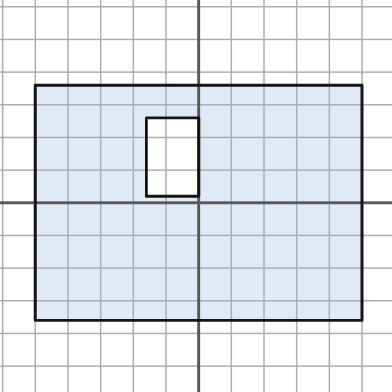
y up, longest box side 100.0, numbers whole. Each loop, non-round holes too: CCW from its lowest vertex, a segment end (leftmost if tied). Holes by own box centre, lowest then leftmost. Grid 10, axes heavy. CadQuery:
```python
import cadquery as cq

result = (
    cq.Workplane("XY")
    .moveTo(-50.0, -36.0)
    .lineTo(50.0, -36.0)
    .lineTo(50.0, 36.0)
    .lineTo(-50.0, 36.0)
    .close()
    .moveTo(-16.0, 2.0)
    .lineTo(0.0, 2.0)
    .lineTo(0.0, 26.0)
    .lineTo(-16.0, 26.0)
    .close()
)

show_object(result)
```